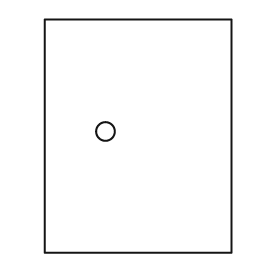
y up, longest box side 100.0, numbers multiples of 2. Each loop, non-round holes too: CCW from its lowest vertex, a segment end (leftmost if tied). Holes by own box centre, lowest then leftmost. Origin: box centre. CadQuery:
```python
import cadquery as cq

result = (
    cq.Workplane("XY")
    .moveTo(-40.0, -50.0)
    .lineTo(40.0, -50.0)
    .lineTo(40.0, 50.0)
    .lineTo(-40.0, 50.0)
    .close()
    .moveTo(-14.0, 2.0)
    .circle(4.0)
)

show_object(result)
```